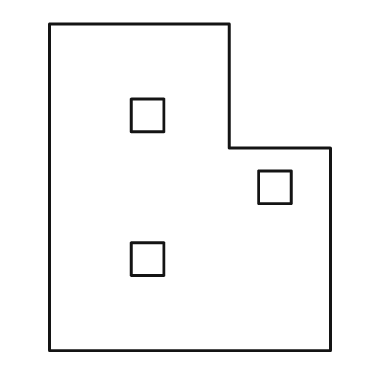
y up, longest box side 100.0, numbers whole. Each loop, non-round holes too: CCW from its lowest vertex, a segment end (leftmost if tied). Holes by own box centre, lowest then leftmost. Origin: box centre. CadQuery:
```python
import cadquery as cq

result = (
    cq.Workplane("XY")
    .moveTo(-43.0, -50.0)
    .lineTo(43.0, -50.0)
    .lineTo(43.0, 12.0)
    .lineTo(12.0, 12.0)
    .lineTo(12.0, 50.0)
    .lineTo(-43.0, 50.0)
    .close()
    .moveTo(-18.0, -27.0)
    .lineTo(-8.0, -27.0)
    .lineTo(-8.0, -17.0)
    .lineTo(-18.0, -17.0)
    .close()
    .moveTo(21.0, -5.0)
    .lineTo(31.0, -5.0)
    .lineTo(31.0, 5.0)
    .lineTo(21.0, 5.0)
    .close()
    .moveTo(-18.0, 17.0)
    .lineTo(-8.0, 17.0)
    .lineTo(-8.0, 27.0)
    .lineTo(-18.0, 27.0)
    .close()
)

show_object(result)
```